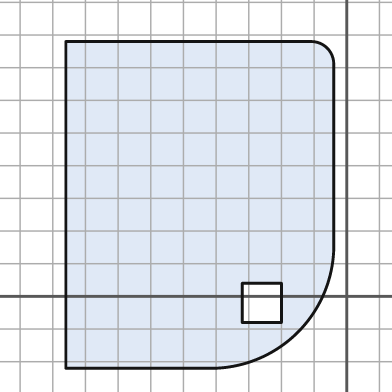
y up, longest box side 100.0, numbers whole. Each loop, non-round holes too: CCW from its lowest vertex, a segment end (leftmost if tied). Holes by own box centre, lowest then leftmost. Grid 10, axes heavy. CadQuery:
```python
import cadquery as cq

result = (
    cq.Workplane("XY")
    .moveTo(-86.0, -22.0)
    .lineTo(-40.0, -22.0)
    .threePointArc((-15.0, -11.0), (-4.0, 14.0))
    .lineTo(-4.0, 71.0)
    .threePointArc((-6.0, 76.0), (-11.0, 78.0))
    .lineTo(-86.0, 78.0)
    .close()
    .moveTo(-32.0, -8.0)
    .lineTo(-20.0, -8.0)
    .lineTo(-20.0, 4.0)
    .lineTo(-32.0, 4.0)
    .close()
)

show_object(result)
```